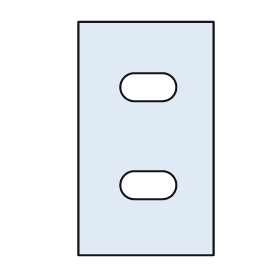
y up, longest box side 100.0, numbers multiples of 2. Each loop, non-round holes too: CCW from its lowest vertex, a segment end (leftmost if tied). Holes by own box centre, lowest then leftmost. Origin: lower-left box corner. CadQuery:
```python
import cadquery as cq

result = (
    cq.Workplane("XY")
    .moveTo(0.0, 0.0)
    .lineTo(58.0, 0.0)
    .lineTo(58.0, 100.0)
    .lineTo(0.0, 100.0)
    .close()
    .moveTo(24.0, 24.0)
    .lineTo(36.0, 24.0)
    .threePointArc((42.0, 30.0), (36.0, 36.0))
    .lineTo(24.0, 36.0)
    .threePointArc((18.0, 30.0), (24.0, 24.0))
    .close()
    .moveTo(24.0, 66.0)
    .lineTo(36.0, 66.0)
    .threePointArc((42.0, 72.0), (36.0, 78.0))
    .lineTo(24.0, 78.0)
    .threePointArc((18.0, 72.0), (24.0, 66.0))
    .close()
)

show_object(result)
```